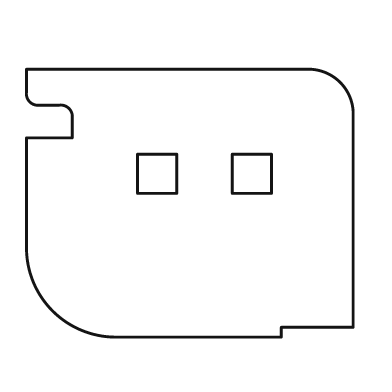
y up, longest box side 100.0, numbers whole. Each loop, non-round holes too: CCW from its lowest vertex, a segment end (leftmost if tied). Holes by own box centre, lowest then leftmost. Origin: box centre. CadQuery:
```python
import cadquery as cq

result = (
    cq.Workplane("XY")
    .moveTo(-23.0, -41.0)
    .lineTo(28.0, -41.0)
    .lineTo(28.0, -38.0)
    .lineTo(50.0, -38.0)
    .lineTo(50.0, 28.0)
    .threePointArc((46.0, 37.0), (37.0, 41.0))
    .lineTo(-50.0, 41.0)
    .lineTo(-50.0, 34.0)
    .threePointArc((-49.0, 31.0), (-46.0, 30.0))
    .lineTo(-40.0, 30.0)
    .threePointArc((-37.0, 29.0), (-36.0, 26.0))
    .lineTo(-36.0, 20.0)
    .lineTo(-50.0, 20.0)
    .lineTo(-50.0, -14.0)
    .threePointArc((-42.0, -33.0), (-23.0, -41.0))
    .close()
    .moveTo(-16.0, 3.0)
    .lineTo(-4.0, 3.0)
    .lineTo(-4.0, 15.0)
    .lineTo(-16.0, 15.0)
    .close()
    .moveTo(13.0, 3.0)
    .lineTo(25.0, 3.0)
    .lineTo(25.0, 15.0)
    .lineTo(13.0, 15.0)
    .close()
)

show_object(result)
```